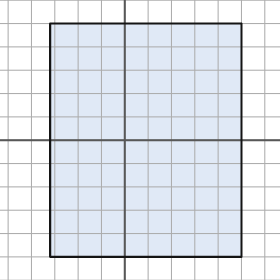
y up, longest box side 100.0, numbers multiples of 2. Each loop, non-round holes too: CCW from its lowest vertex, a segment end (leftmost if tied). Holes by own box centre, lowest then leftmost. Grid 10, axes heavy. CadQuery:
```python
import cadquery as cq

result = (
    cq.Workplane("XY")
    .moveTo(-32.0, -50.0)
    .lineTo(50.0, -50.0)
    .lineTo(50.0, 50.0)
    .lineTo(-32.0, 50.0)
    .close()
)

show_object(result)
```